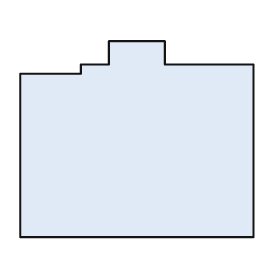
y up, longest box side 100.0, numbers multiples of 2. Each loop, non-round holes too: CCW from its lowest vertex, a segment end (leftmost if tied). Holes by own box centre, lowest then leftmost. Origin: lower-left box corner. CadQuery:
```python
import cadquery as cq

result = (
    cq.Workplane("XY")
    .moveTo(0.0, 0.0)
    .lineTo(100.0, 0.0)
    .lineTo(100.0, 74.0)
    .lineTo(62.0, 74.0)
    .lineTo(62.0, 84.0)
    .lineTo(38.0, 84.0)
    .lineTo(38.0, 74.0)
    .lineTo(26.0, 74.0)
    .lineTo(26.0, 70.0)
    .lineTo(0.0, 70.0)
    .close()
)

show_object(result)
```